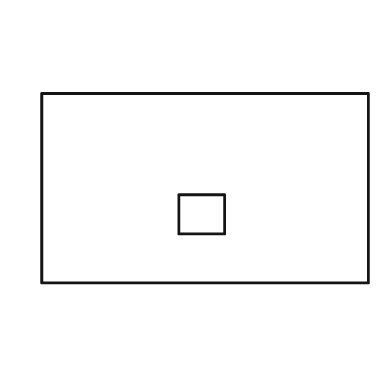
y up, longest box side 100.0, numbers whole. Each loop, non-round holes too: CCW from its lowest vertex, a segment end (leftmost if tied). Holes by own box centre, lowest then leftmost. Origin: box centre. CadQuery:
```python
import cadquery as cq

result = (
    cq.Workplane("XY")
    .moveTo(-50.0, -29.0)
    .lineTo(50.0, -29.0)
    .lineTo(50.0, 29.0)
    .lineTo(-50.0, 29.0)
    .close()
    .moveTo(-8.0, -14.0)
    .lineTo(6.0, -14.0)
    .lineTo(6.0, -2.0)
    .lineTo(-8.0, -2.0)
    .close()
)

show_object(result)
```